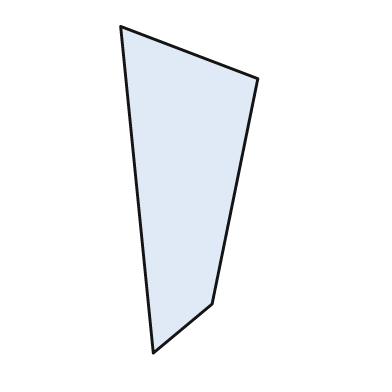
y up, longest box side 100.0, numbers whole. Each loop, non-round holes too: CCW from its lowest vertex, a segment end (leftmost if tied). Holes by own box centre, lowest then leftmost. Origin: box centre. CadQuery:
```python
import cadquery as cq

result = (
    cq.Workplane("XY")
    .moveTo(-11.0, -50.0)
    .lineTo(7.0, -35.0)
    .lineTo(21.0, 34.0)
    .lineTo(-21.0, 50.0)
    .close()
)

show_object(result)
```